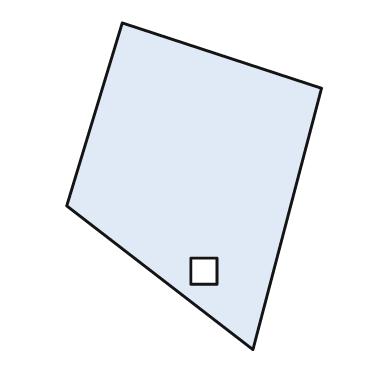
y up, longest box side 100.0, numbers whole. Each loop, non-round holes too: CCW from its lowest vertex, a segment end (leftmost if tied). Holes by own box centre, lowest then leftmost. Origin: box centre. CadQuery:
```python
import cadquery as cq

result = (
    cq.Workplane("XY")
    .moveTo(18.0, -50.0)
    .lineTo(39.0, 30.0)
    .lineTo(-22.0, 50.0)
    .lineTo(-39.0, -6.0)
    .close()
    .moveTo(-1.0, -30.0)
    .lineTo(7.0, -30.0)
    .lineTo(7.0, -22.0)
    .lineTo(-1.0, -22.0)
    .close()
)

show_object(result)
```